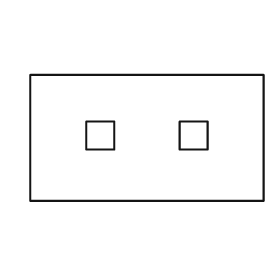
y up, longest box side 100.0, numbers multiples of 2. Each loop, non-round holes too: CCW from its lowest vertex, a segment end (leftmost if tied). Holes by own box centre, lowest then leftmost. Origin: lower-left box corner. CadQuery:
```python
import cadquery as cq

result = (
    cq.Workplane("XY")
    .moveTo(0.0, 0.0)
    .lineTo(100.0, 0.0)
    .lineTo(100.0, 54.0)
    .lineTo(0.0, 54.0)
    .close()
    .moveTo(24.0, 22.0)
    .lineTo(36.0, 22.0)
    .lineTo(36.0, 34.0)
    .lineTo(24.0, 34.0)
    .close()
    .moveTo(64.0, 22.0)
    .lineTo(76.0, 22.0)
    .lineTo(76.0, 34.0)
    .lineTo(64.0, 34.0)
    .close()
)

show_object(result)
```